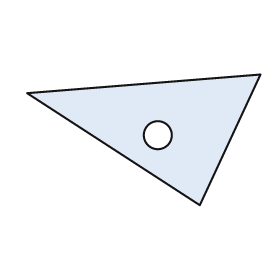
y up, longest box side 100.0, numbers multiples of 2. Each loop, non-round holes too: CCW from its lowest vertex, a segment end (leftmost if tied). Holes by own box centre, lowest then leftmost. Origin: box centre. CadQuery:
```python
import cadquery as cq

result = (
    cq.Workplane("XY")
    .moveTo(24.0, -28.0)
    .lineTo(50.0, 28.0)
    .lineTo(-50.0, 20.0)
    .close()
    .moveTo(6.0, 2.0)
    .circle(6.0)
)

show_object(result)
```